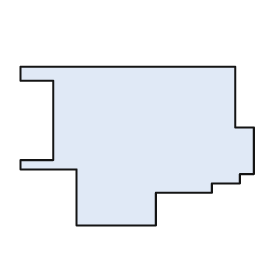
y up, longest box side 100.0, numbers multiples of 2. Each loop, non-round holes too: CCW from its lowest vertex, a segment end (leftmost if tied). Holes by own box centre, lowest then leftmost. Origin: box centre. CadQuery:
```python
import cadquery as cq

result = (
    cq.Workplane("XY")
    .moveTo(-26.0, -34.0)
    .lineTo(8.0, -34.0)
    .lineTo(8.0, -20.0)
    .lineTo(32.0, -20.0)
    .lineTo(32.0, -16.0)
    .lineTo(44.0, -16.0)
    .lineTo(44.0, -12.0)
    .lineTo(50.0, -12.0)
    .lineTo(50.0, 8.0)
    .lineTo(42.0, 8.0)
    .lineTo(42.0, 34.0)
    .lineTo(-50.0, 34.0)
    .lineTo(-50.0, 28.0)
    .lineTo(-36.0, 28.0)
    .lineTo(-36.0, -6.0)
    .lineTo(-50.0, -6.0)
    .lineTo(-50.0, -10.0)
    .lineTo(-26.0, -10.0)
    .close()
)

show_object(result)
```